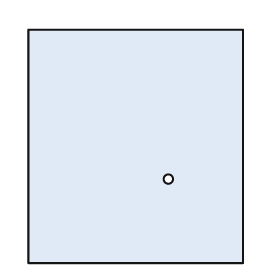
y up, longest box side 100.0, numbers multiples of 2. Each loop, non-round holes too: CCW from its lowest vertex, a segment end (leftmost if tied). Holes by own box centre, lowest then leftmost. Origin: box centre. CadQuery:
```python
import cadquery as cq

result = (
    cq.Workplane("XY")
    .moveTo(-46.0, -50.0)
    .lineTo(46.0, -50.0)
    .lineTo(46.0, 50.0)
    .lineTo(-46.0, 50.0)
    .close()
    .moveTo(14.0, -14.0)
    .circle(2.0)
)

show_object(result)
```